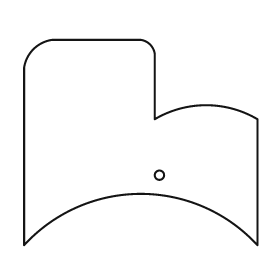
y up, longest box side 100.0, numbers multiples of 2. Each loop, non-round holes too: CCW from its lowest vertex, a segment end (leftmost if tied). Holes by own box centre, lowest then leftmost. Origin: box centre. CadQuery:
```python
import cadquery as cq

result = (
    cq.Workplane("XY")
    .moveTo(-50.0, -44.0)
    .threePointArc((0.0, -22.0), (50.0, -44.0))
    .lineTo(50.0, 10.0)
    .threePointArc((28.0, 16.0), (6.0, 10.0))
    .lineTo(6.0, 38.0)
    .threePointArc((4.0, 42.0), (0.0, 44.0))
    .lineTo(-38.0, 44.0)
    .threePointArc((-46.0, 40.0), (-50.0, 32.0))
    .close()
    .moveTo(8.0, -14.0)
    .circle(2.0)
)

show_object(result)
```